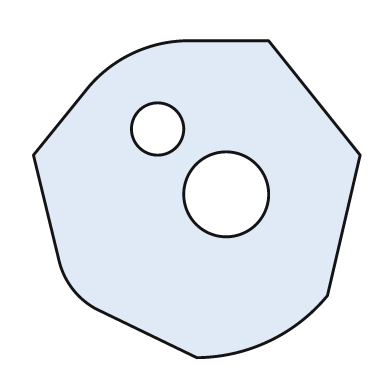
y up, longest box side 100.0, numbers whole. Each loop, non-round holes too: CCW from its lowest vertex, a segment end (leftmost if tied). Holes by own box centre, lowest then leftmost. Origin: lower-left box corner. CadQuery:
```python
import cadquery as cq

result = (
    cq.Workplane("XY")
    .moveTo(50.0, 0.0)
    .threePointArc((72.0, 5.0), (90.0, 19.0))
    .lineTo(100.0, 62.0)
    .lineTo(72.0, 97.0)
    .lineTo(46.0, 97.0)
    .threePointArc((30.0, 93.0), (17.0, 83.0))
    .lineTo(0.0, 62.0)
    .lineTo(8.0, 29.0)
    .threePointArc((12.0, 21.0), (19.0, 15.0))
    .close()
    .moveTo(59.0, 50.0)
    .circle(13.0)
    .moveTo(38.0, 70.0)
    .circle(8.0)
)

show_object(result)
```